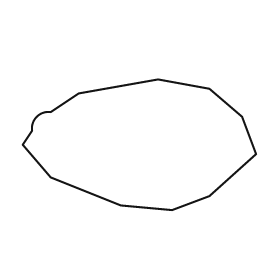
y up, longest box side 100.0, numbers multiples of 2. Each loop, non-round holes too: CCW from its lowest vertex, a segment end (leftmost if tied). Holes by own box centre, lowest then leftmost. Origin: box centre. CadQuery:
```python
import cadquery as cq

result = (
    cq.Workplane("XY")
    .moveTo(14.0, -28.0)
    .lineTo(30.0, -22.0)
    .lineTo(50.0, -4.0)
    .lineTo(44.0, 12.0)
    .lineTo(30.0, 24.0)
    .lineTo(8.0, 28.0)
    .lineTo(-26.0, 22.0)
    .lineTo(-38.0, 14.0)
    .threePointArc((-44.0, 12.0), (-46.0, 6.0))
    .lineTo(-50.0, 0.0)
    .lineTo(-38.0, -14.0)
    .lineTo(-8.0, -26.0)
    .close()
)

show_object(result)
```